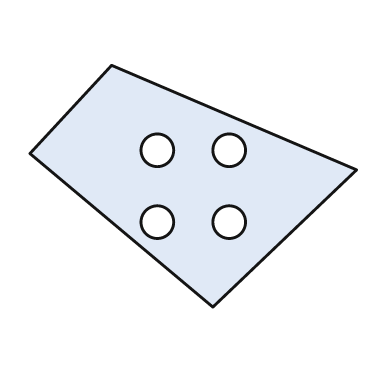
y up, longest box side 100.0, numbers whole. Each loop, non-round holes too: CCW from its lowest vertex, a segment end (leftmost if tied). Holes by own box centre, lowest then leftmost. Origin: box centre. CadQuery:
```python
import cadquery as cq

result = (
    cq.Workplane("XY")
    .moveTo(6.0, -37.0)
    .lineTo(50.0, 5.0)
    .lineTo(-25.0, 37.0)
    .lineTo(-50.0, 10.0)
    .close()
    .moveTo(-11.0, -11.0)
    .circle(5.0)
    .moveTo(11.0, -11.0)
    .circle(5.0)
    .moveTo(-11.0, 11.0)
    .circle(5.0)
    .moveTo(11.0, 11.0)
    .circle(5.0)
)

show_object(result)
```